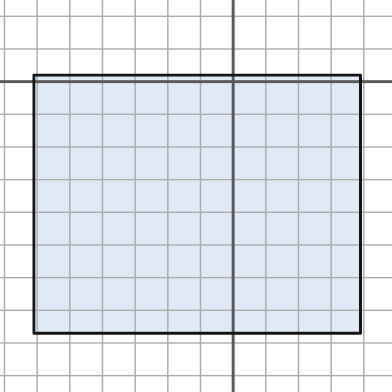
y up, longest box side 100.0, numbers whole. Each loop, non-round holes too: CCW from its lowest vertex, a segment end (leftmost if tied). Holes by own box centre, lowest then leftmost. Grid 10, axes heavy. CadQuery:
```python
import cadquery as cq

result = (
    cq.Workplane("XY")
    .moveTo(-61.0, -77.0)
    .lineTo(39.0, -77.0)
    .lineTo(39.0, 2.0)
    .lineTo(-61.0, 2.0)
    .close()
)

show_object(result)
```